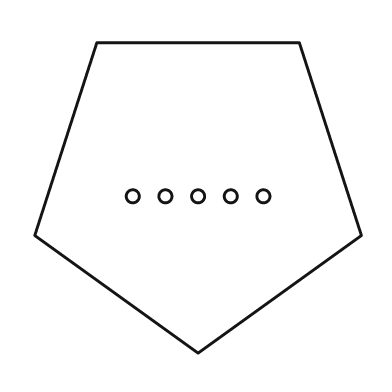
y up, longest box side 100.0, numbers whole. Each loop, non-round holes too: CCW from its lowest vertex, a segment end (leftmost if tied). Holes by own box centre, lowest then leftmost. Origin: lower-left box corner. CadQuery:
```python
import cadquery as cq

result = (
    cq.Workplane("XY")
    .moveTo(50.0, 0.0)
    .lineTo(100.0, 36.0)
    .lineTo(81.0, 95.0)
    .lineTo(19.0, 95.0)
    .lineTo(0.0, 36.0)
    .close()
    .moveTo(30.0, 48.0)
    .circle(2.0)
    .moveTo(40.0, 48.0)
    .circle(2.0)
    .moveTo(50.0, 48.0)
    .circle(2.0)
    .moveTo(60.0, 48.0)
    .circle(2.0)
    .moveTo(70.0, 48.0)
    .circle(2.0)
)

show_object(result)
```